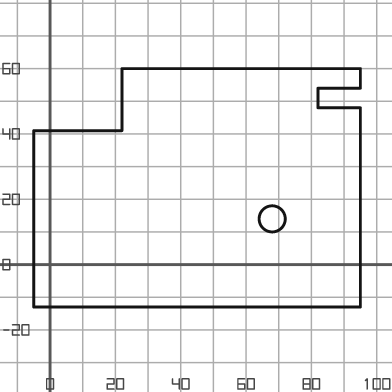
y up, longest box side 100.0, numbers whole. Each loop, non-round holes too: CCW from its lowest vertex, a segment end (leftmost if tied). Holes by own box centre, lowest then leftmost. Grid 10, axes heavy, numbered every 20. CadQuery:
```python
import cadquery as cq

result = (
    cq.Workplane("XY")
    .moveTo(-5.0, -13.0)
    .lineTo(95.0, -13.0)
    .lineTo(95.0, 48.0)
    .lineTo(82.0, 48.0)
    .lineTo(82.0, 54.0)
    .lineTo(95.0, 54.0)
    .lineTo(95.0, 60.0)
    .lineTo(22.0, 60.0)
    .lineTo(22.0, 41.0)
    .lineTo(-5.0, 41.0)
    .close()
    .moveTo(68.0, 14.0)
    .circle(4.0)
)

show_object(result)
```